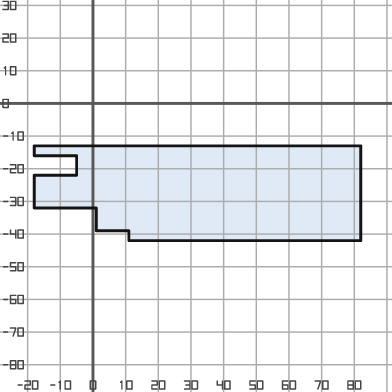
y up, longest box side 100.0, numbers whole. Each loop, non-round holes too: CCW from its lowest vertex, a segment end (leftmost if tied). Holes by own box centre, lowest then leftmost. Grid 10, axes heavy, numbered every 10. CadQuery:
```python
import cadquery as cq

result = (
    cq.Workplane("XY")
    .moveTo(11.0, -42.0)
    .lineTo(82.0, -42.0)
    .lineTo(82.0, -13.0)
    .lineTo(-18.0, -13.0)
    .lineTo(-18.0, -16.0)
    .lineTo(-5.0, -16.0)
    .lineTo(-5.0, -22.0)
    .lineTo(-18.0, -22.0)
    .lineTo(-18.0, -32.0)
    .lineTo(1.0, -32.0)
    .lineTo(1.0, -39.0)
    .lineTo(11.0, -39.0)
    .close()
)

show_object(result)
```